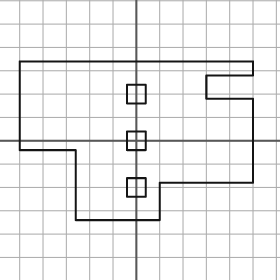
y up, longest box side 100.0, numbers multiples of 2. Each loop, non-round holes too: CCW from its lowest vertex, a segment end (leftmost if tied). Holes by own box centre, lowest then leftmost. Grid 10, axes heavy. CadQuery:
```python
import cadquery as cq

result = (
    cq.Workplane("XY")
    .moveTo(-26.0, -34.0)
    .lineTo(10.0, -34.0)
    .lineTo(10.0, -18.0)
    .lineTo(50.0, -18.0)
    .lineTo(50.0, 18.0)
    .lineTo(30.0, 18.0)
    .lineTo(30.0, 28.0)
    .lineTo(50.0, 28.0)
    .lineTo(50.0, 34.0)
    .lineTo(-50.0, 34.0)
    .lineTo(-50.0, -4.0)
    .lineTo(-26.0, -4.0)
    .close()
    .moveTo(-4.0, -24.0)
    .lineTo(4.0, -24.0)
    .lineTo(4.0, -16.0)
    .lineTo(-4.0, -16.0)
    .close()
    .moveTo(-4.0, -4.0)
    .lineTo(4.0, -4.0)
    .lineTo(4.0, 4.0)
    .lineTo(-4.0, 4.0)
    .close()
    .moveTo(-4.0, 16.0)
    .lineTo(4.0, 16.0)
    .lineTo(4.0, 24.0)
    .lineTo(-4.0, 24.0)
    .close()
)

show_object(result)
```